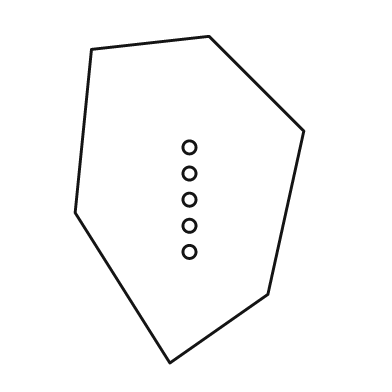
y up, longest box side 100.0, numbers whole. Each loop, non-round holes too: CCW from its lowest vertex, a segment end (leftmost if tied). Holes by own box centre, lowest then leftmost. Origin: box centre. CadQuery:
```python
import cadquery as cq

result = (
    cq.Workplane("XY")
    .moveTo(-6.0, -50.0)
    .lineTo(24.0, -29.0)
    .lineTo(35.0, 21.0)
    .lineTo(6.0, 50.0)
    .lineTo(-30.0, 46.0)
    .lineTo(-35.0, -4.0)
    .close()
    .moveTo(0.0, -16.0)
    .circle(2.0)
    .moveTo(0.0, -8.0)
    .circle(2.0)
    .moveTo(0.0, 0.0)
    .circle(2.0)
    .moveTo(0.0, 8.0)
    .circle(2.0)
    .moveTo(0.0, 16.0)
    .circle(2.0)
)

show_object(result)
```